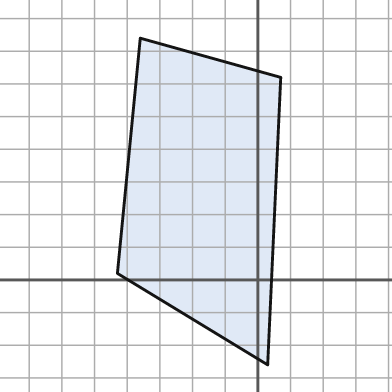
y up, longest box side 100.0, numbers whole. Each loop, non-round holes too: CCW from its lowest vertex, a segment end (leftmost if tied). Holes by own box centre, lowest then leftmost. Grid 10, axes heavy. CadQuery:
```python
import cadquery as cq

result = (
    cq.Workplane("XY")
    .moveTo(3.0, -26.0)
    .lineTo(7.0, 62.0)
    .lineTo(-36.0, 74.0)
    .lineTo(-43.0, 2.0)
    .close()
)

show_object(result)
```